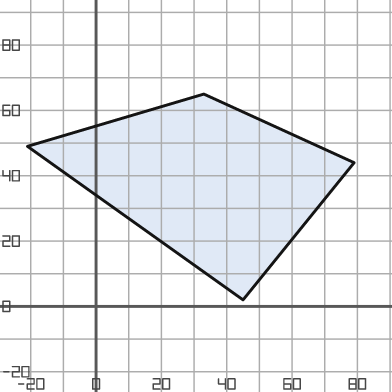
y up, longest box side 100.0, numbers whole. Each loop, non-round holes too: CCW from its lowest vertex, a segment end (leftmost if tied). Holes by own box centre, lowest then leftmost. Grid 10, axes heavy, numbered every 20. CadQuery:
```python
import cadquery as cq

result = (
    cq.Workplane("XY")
    .moveTo(45.0, 2.0)
    .lineTo(79.0, 44.0)
    .lineTo(33.0, 65.0)
    .lineTo(-21.0, 49.0)
    .close()
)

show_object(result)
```